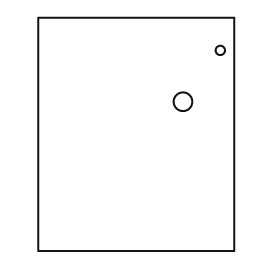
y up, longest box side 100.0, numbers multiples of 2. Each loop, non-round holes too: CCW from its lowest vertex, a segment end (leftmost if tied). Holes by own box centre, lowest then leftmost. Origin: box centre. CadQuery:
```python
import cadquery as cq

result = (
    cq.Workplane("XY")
    .moveTo(-42.0, -50.0)
    .lineTo(42.0, -50.0)
    .lineTo(42.0, 50.0)
    .lineTo(-42.0, 50.0)
    .close()
    .moveTo(20.0, 14.0)
    .circle(4.0)
    .moveTo(36.0, 36.0)
    .circle(2.0)
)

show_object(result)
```